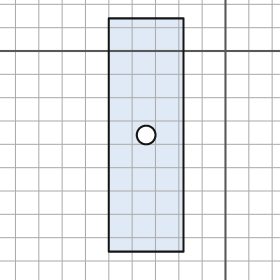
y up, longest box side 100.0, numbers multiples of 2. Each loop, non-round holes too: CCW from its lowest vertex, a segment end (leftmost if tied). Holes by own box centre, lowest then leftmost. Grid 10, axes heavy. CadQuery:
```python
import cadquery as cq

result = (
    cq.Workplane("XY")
    .moveTo(-50.0, -86.0)
    .lineTo(-18.0, -86.0)
    .lineTo(-18.0, 14.0)
    .lineTo(-50.0, 14.0)
    .close()
    .moveTo(-34.0, -36.0)
    .circle(4.0)
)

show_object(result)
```